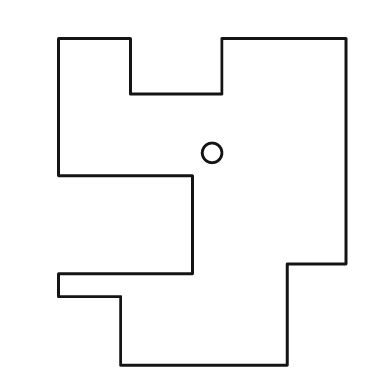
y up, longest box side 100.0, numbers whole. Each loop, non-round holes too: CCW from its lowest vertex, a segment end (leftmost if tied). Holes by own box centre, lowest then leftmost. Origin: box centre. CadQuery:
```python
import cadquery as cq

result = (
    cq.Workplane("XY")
    .moveTo(-25.0, -50.0)
    .lineTo(26.0, -50.0)
    .lineTo(26.0, -19.0)
    .lineTo(44.0, -19.0)
    .lineTo(44.0, 50.0)
    .lineTo(6.0, 50.0)
    .lineTo(6.0, 33.0)
    .lineTo(-22.0, 33.0)
    .lineTo(-22.0, 50.0)
    .lineTo(-44.0, 50.0)
    .lineTo(-44.0, 8.0)
    .lineTo(-3.0, 8.0)
    .lineTo(-3.0, -22.0)
    .lineTo(-44.0, -22.0)
    .lineTo(-44.0, -29.0)
    .lineTo(-25.0, -29.0)
    .close()
    .moveTo(3.0, 15.0)
    .circle(3.0)
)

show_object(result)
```